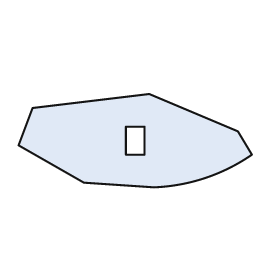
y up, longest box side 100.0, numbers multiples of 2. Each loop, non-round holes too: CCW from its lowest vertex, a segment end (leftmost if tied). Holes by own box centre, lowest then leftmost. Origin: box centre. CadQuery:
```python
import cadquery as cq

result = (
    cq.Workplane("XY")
    .moveTo(8.0, -20.0)
    .threePointArc((30.0, -16.0), (50.0, -6.0))
    .lineTo(44.0, 4.0)
    .lineTo(6.0, 20.0)
    .lineTo(-44.0, 14.0)
    .lineTo(-50.0, -2.0)
    .lineTo(-22.0, -18.0)
    .close()
    .moveTo(-4.0, -6.0)
    .lineTo(4.0, -6.0)
    .lineTo(4.0, 6.0)
    .lineTo(-4.0, 6.0)
    .close()
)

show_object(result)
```